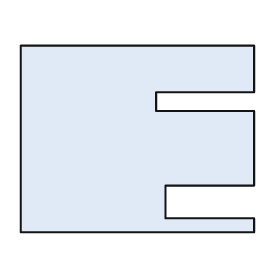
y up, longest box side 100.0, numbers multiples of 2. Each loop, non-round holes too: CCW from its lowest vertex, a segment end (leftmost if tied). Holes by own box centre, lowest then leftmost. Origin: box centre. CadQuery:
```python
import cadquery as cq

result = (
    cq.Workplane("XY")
    .moveTo(-50.0, -40.0)
    .lineTo(50.0, -40.0)
    .lineTo(50.0, -34.0)
    .lineTo(12.0, -34.0)
    .lineTo(12.0, -20.0)
    .lineTo(50.0, -20.0)
    .lineTo(50.0, 12.0)
    .lineTo(8.0, 12.0)
    .lineTo(8.0, 20.0)
    .lineTo(50.0, 20.0)
    .lineTo(50.0, 40.0)
    .lineTo(-50.0, 40.0)
    .close()
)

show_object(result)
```